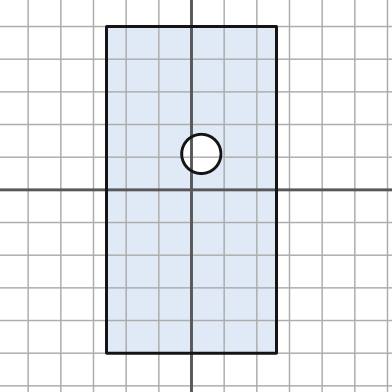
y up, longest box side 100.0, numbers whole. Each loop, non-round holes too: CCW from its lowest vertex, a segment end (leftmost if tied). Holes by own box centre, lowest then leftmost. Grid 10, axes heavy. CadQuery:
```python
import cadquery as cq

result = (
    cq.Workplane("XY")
    .moveTo(-26.0, -50.0)
    .lineTo(26.0, -50.0)
    .lineTo(26.0, 50.0)
    .lineTo(-26.0, 50.0)
    .close()
    .moveTo(3.0, 11.0)
    .circle(6.0)
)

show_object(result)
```